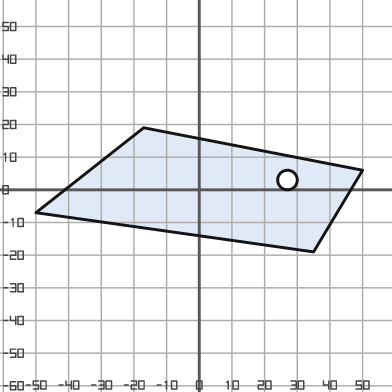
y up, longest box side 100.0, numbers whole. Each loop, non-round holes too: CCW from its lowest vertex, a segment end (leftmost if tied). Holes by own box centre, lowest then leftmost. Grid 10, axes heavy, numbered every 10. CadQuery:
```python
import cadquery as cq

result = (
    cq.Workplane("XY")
    .moveTo(35.0, -19.0)
    .lineTo(50.0, 6.0)
    .lineTo(-17.0, 19.0)
    .lineTo(-50.0, -7.0)
    .close()
    .moveTo(27.0, 3.0)
    .circle(3.0)
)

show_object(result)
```